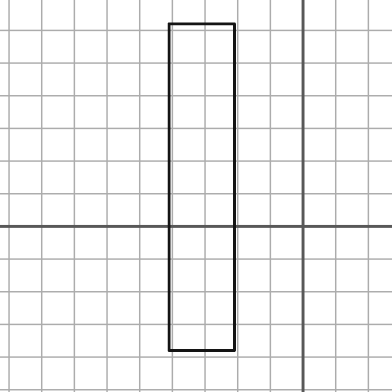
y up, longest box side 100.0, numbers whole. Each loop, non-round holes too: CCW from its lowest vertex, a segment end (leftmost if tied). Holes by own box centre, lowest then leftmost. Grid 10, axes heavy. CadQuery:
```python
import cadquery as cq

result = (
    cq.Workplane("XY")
    .moveTo(-41.0, -38.0)
    .lineTo(-21.0, -38.0)
    .lineTo(-21.0, 62.0)
    .lineTo(-41.0, 62.0)
    .close()
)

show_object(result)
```